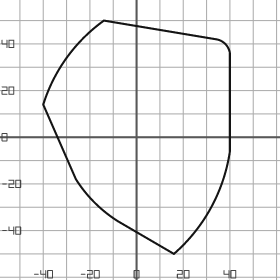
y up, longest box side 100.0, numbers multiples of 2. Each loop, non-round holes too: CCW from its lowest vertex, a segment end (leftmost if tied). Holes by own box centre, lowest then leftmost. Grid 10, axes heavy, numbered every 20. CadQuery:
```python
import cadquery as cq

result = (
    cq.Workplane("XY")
    .moveTo(16.0, -50.0)
    .threePointArc((32.0, -30.0), (40.0, -6.0))
    .lineTo(40.0, 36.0)
    .threePointArc((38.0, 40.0), (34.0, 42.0))
    .lineTo(-14.0, 50.0)
    .threePointArc((-30.0, 34.0), (-40.0, 14.0))
    .lineTo(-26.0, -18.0)
    .threePointArc((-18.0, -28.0), (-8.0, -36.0))
    .close()
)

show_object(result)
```